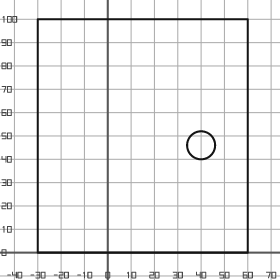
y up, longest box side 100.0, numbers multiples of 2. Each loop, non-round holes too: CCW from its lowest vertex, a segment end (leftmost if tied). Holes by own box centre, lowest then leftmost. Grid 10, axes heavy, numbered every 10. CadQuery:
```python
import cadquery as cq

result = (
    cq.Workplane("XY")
    .moveTo(-30.0, 0.0)
    .lineTo(60.0, 0.0)
    .lineTo(60.0, 100.0)
    .lineTo(-30.0, 100.0)
    .close()
    .moveTo(40.0, 46.0)
    .circle(6.0)
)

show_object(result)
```